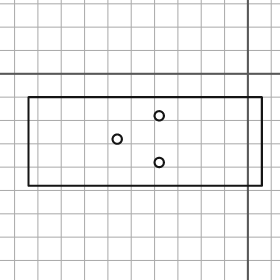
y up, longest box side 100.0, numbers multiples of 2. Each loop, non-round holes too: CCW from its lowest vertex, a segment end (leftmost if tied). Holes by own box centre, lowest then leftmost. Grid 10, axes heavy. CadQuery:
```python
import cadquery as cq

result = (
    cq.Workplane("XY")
    .moveTo(-94.0, -48.0)
    .lineTo(6.0, -48.0)
    .lineTo(6.0, -10.0)
    .lineTo(-94.0, -10.0)
    .close()
    .moveTo(-38.0, -38.0)
    .circle(2.0)
    .moveTo(-56.0, -28.0)
    .circle(2.0)
    .moveTo(-38.0, -18.0)
    .circle(2.0)
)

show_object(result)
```